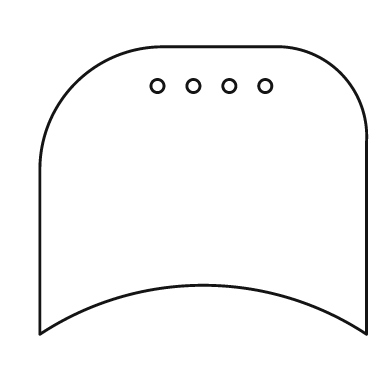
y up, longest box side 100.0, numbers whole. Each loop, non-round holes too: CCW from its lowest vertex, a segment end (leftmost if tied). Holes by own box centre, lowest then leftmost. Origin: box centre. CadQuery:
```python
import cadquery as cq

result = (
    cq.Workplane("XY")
    .moveTo(-50.0, -44.0)
    .threePointArc((0.0, -29.0), (50.0, -44.0))
    .lineTo(50.0, 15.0)
    .threePointArc((42.0, 36.0), (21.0, 44.0))
    .lineTo(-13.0, 44.0)
    .threePointArc((-39.0, 33.0), (-50.0, 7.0))
    .close()
    .moveTo(-14.0, 32.0)
    .circle(2.0)
    .moveTo(-3.0, 32.0)
    .circle(2.0)
    .moveTo(8.0, 32.0)
    .circle(2.0)
    .moveTo(19.0, 32.0)
    .circle(2.0)
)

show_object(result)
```